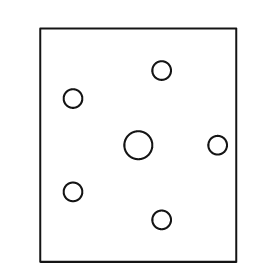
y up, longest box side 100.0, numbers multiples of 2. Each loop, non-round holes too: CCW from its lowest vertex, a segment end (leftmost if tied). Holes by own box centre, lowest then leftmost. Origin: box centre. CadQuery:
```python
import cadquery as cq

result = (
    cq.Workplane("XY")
    .moveTo(-42.0, -50.0)
    .lineTo(42.0, -50.0)
    .lineTo(42.0, 50.0)
    .lineTo(-42.0, 50.0)
    .close()
    .moveTo(10.0, -32.0)
    .circle(4.0)
    .moveTo(-28.0, -20.0)
    .circle(4.0)
    .moveTo(0.0, 0.0)
    .circle(6.0)
    .moveTo(34.0, 0.0)
    .circle(4.0)
    .moveTo(-28.0, 20.0)
    .circle(4.0)
    .moveTo(10.0, 32.0)
    .circle(4.0)
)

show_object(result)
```